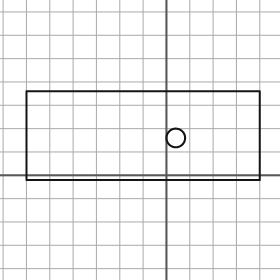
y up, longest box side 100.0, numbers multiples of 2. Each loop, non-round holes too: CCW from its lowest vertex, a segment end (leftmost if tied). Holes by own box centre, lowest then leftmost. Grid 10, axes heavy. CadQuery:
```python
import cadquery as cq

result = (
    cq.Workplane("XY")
    .moveTo(-60.0, -2.0)
    .lineTo(40.0, -2.0)
    .lineTo(40.0, 36.0)
    .lineTo(-60.0, 36.0)
    .close()
    .moveTo(4.0, 16.0)
    .circle(4.0)
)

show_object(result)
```